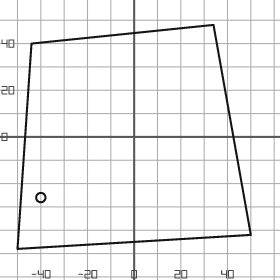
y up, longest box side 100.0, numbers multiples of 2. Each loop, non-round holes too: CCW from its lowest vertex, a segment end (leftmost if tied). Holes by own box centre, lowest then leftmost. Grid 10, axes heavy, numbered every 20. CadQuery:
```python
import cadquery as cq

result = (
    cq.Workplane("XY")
    .moveTo(-50.0, -48.0)
    .lineTo(50.0, -42.0)
    .lineTo(34.0, 48.0)
    .lineTo(-44.0, 40.0)
    .close()
    .moveTo(-40.0, -26.0)
    .circle(2.0)
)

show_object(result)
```